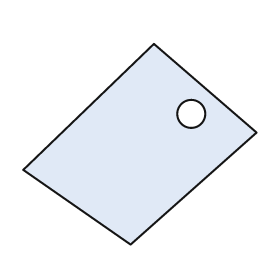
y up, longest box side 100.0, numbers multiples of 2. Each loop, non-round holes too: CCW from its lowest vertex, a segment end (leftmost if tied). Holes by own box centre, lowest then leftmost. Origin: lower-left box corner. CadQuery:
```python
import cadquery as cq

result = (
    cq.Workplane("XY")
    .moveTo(46.0, 0.0)
    .lineTo(100.0, 48.0)
    .lineTo(56.0, 86.0)
    .lineTo(0.0, 32.0)
    .close()
    .moveTo(72.0, 56.0)
    .circle(6.0)
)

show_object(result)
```